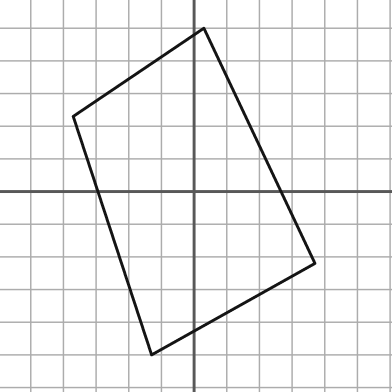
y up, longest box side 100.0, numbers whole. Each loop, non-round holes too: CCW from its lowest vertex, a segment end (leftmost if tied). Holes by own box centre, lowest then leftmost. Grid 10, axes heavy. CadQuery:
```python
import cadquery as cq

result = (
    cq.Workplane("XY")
    .moveTo(-13.0, -50.0)
    .lineTo(37.0, -22.0)
    .lineTo(3.0, 50.0)
    .lineTo(-37.0, 23.0)
    .close()
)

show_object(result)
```